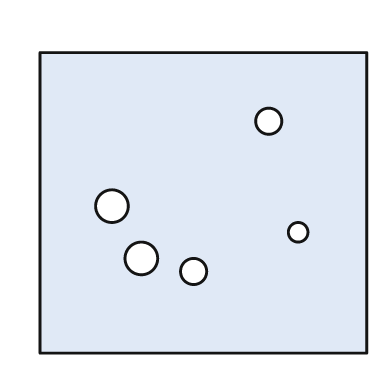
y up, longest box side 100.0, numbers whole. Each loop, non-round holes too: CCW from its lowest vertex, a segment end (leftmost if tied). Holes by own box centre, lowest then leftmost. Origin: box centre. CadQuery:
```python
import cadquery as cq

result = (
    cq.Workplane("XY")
    .moveTo(-50.0, -46.0)
    .lineTo(50.0, -46.0)
    .lineTo(50.0, 46.0)
    .lineTo(-50.0, 46.0)
    .close()
    .moveTo(-3.0, -21.0)
    .circle(4.0)
    .moveTo(-19.0, -17.0)
    .circle(5.0)
    .moveTo(29.0, -9.0)
    .circle(3.0)
    .moveTo(-28.0, -1.0)
    .circle(5.0)
    .moveTo(20.0, 25.0)
    .circle(4.0)
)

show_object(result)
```